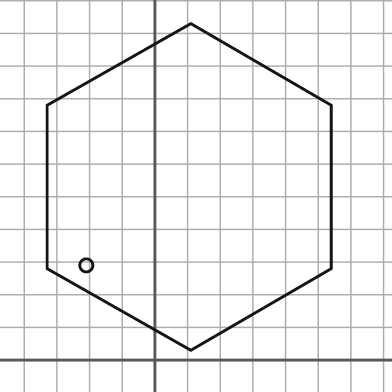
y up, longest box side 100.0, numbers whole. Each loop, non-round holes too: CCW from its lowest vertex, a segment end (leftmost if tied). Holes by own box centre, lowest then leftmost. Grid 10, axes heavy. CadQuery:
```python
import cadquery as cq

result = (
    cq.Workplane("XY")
    .moveTo(11.0, 3.0)
    .lineTo(54.0, 28.0)
    .lineTo(54.0, 78.0)
    .lineTo(11.0, 103.0)
    .lineTo(-33.0, 78.0)
    .lineTo(-33.0, 28.0)
    .close()
    .moveTo(-21.0, 29.0)
    .circle(2.0)
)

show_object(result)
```